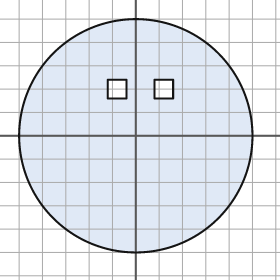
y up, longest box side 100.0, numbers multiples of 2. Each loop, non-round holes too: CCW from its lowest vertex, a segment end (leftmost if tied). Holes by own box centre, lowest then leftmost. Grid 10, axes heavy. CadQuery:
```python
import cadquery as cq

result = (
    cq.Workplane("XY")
    .moveTo(0.0, 0.0)
    .circle(50.0)
    .moveTo(-12.0, 16.0)
    .lineTo(-4.0, 16.0)
    .lineTo(-4.0, 24.0)
    .lineTo(-12.0, 24.0)
    .close()
    .moveTo(8.0, 16.0)
    .lineTo(16.0, 16.0)
    .lineTo(16.0, 24.0)
    .lineTo(8.0, 24.0)
    .close()
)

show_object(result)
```